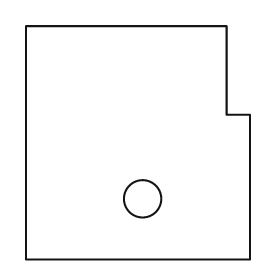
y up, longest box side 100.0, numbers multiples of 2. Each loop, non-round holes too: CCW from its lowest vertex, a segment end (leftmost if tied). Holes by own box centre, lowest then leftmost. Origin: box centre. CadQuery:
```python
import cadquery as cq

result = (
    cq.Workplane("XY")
    .moveTo(-48.0, -50.0)
    .lineTo(48.0, -50.0)
    .lineTo(48.0, 12.0)
    .lineTo(38.0, 12.0)
    .lineTo(38.0, 50.0)
    .lineTo(-48.0, 50.0)
    .close()
    .moveTo(2.0, -24.0)
    .circle(8.0)
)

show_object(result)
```